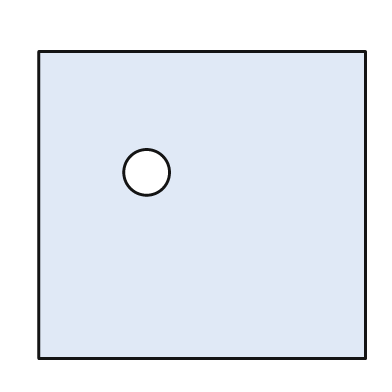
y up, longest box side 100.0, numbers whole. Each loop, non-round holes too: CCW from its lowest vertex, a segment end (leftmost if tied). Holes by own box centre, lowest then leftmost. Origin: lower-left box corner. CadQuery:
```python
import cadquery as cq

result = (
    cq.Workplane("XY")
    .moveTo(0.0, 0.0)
    .lineTo(100.0, 0.0)
    .lineTo(100.0, 94.0)
    .lineTo(0.0, 94.0)
    .close()
    .moveTo(33.0, 57.0)
    .circle(7.0)
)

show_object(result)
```